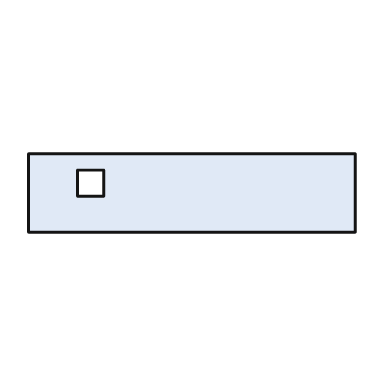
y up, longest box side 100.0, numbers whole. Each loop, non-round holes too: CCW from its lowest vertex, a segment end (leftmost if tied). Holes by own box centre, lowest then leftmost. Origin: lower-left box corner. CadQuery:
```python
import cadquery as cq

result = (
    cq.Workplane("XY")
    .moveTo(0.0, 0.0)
    .lineTo(100.0, 0.0)
    .lineTo(100.0, 24.0)
    .lineTo(0.0, 24.0)
    .close()
    .moveTo(15.0, 11.0)
    .lineTo(23.0, 11.0)
    .lineTo(23.0, 19.0)
    .lineTo(15.0, 19.0)
    .close()
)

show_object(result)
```